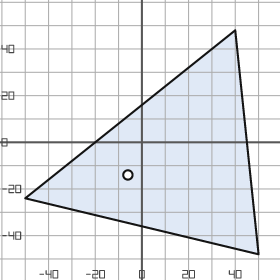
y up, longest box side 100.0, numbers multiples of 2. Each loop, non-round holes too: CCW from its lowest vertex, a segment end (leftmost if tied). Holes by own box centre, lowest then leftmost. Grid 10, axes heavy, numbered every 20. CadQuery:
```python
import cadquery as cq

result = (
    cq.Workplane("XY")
    .moveTo(50.0, -48.0)
    .lineTo(40.0, 48.0)
    .lineTo(-50.0, -24.0)
    .close()
    .moveTo(-6.0, -14.0)
    .circle(2.0)
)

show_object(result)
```